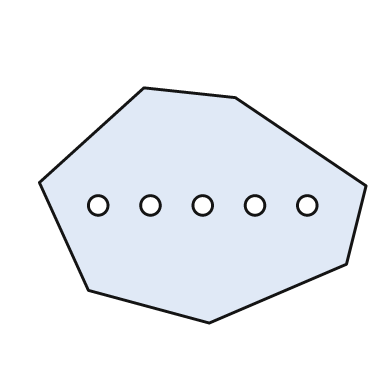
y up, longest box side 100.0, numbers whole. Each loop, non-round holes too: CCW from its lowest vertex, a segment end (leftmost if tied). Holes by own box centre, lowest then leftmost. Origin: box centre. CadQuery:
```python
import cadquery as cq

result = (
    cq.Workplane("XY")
    .moveTo(2.0, -36.0)
    .lineTo(44.0, -18.0)
    .lineTo(50.0, 6.0)
    .lineTo(10.0, 33.0)
    .lineTo(-18.0, 36.0)
    .lineTo(-50.0, 7.0)
    .lineTo(-35.0, -26.0)
    .close()
    .moveTo(-32.0, 0.0)
    .circle(3.0)
    .moveTo(-16.0, 0.0)
    .circle(3.0)
    .moveTo(0.0, 0.0)
    .circle(3.0)
    .moveTo(16.0, 0.0)
    .circle(3.0)
    .moveTo(32.0, 0.0)
    .circle(3.0)
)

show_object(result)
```